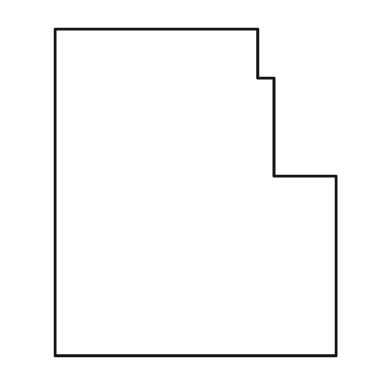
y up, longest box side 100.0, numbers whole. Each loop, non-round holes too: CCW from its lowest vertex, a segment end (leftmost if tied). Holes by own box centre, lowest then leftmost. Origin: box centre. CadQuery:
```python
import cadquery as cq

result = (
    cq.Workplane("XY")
    .moveTo(-43.0, -50.0)
    .lineTo(43.0, -50.0)
    .lineTo(43.0, 5.0)
    .lineTo(24.0, 5.0)
    .lineTo(24.0, 35.0)
    .lineTo(19.0, 35.0)
    .lineTo(19.0, 50.0)
    .lineTo(-43.0, 50.0)
    .close()
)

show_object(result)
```